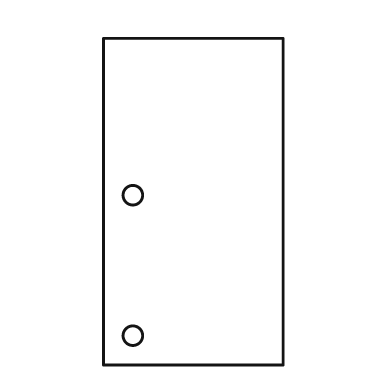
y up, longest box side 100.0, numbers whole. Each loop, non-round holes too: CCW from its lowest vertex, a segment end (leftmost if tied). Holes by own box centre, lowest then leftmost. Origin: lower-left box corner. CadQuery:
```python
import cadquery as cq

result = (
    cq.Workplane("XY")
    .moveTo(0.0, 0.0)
    .lineTo(55.0, 0.0)
    .lineTo(55.0, 100.0)
    .lineTo(0.0, 100.0)
    .close()
    .moveTo(9.0, 9.0)
    .circle(3.0)
    .moveTo(9.0, 52.0)
    .circle(3.0)
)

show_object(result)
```